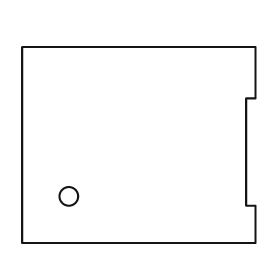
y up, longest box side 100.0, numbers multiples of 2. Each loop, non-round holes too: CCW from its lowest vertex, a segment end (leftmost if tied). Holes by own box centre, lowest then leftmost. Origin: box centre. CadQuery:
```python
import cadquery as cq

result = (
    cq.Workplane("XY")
    .moveTo(-50.0, -42.0)
    .lineTo(50.0, -42.0)
    .lineTo(50.0, -26.0)
    .lineTo(46.0, -26.0)
    .lineTo(46.0, 20.0)
    .lineTo(50.0, 20.0)
    .lineTo(50.0, 42.0)
    .lineTo(-50.0, 42.0)
    .close()
    .moveTo(-30.0, -22.0)
    .circle(4.0)
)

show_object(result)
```